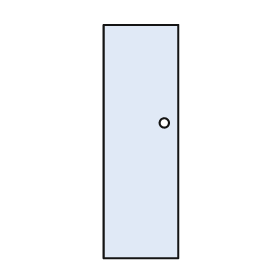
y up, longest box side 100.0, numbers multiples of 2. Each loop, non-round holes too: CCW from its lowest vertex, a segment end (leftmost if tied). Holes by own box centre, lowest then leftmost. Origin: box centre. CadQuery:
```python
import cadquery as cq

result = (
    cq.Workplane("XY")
    .moveTo(-16.0, -50.0)
    .lineTo(16.0, -50.0)
    .lineTo(16.0, 50.0)
    .lineTo(-16.0, 50.0)
    .close()
    .moveTo(10.0, 8.0)
    .circle(2.0)
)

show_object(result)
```